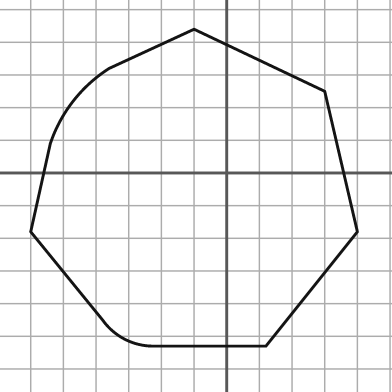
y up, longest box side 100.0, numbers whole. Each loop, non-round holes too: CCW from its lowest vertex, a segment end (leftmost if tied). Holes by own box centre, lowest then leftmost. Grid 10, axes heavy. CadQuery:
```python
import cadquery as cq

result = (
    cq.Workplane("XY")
    .moveTo(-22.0, -53.0)
    .lineTo(12.0, -53.0)
    .lineTo(40.0, -18.0)
    .lineTo(30.0, 25.0)
    .lineTo(-10.0, 44.0)
    .lineTo(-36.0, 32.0)
    .threePointArc((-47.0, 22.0), (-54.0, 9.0))
    .lineTo(-60.0, -18.0)
    .lineTo(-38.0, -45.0)
    .threePointArc((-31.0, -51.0), (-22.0, -53.0))
    .close()
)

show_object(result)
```